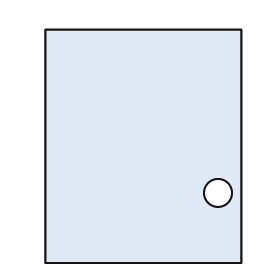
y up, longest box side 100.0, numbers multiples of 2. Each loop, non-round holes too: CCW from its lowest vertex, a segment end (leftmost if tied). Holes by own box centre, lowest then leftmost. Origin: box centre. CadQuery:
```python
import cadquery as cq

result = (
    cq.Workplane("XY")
    .moveTo(-42.0, -50.0)
    .lineTo(42.0, -50.0)
    .lineTo(42.0, 50.0)
    .lineTo(-42.0, 50.0)
    .close()
    .moveTo(32.0, -20.0)
    .circle(6.0)
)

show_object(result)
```